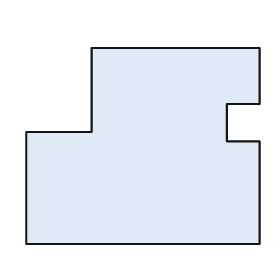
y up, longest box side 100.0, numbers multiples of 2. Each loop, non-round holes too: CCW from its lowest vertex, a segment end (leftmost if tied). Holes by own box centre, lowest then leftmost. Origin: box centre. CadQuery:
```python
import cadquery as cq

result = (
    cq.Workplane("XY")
    .moveTo(-50.0, -42.0)
    .lineTo(50.0, -42.0)
    .lineTo(50.0, 2.0)
    .lineTo(36.0, 2.0)
    .lineTo(36.0, 18.0)
    .lineTo(50.0, 18.0)
    .lineTo(50.0, 42.0)
    .lineTo(-22.0, 42.0)
    .lineTo(-22.0, 6.0)
    .lineTo(-50.0, 6.0)
    .close()
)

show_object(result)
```